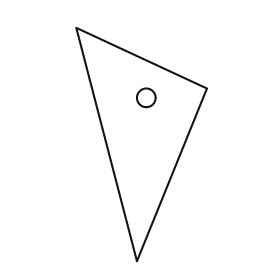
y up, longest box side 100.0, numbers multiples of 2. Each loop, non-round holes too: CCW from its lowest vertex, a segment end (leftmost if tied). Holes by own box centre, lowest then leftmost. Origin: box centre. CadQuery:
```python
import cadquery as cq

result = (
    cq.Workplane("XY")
    .moveTo(-2.0, -50.0)
    .lineTo(28.0, 24.0)
    .lineTo(-28.0, 50.0)
    .close()
    .moveTo(2.0, 20.0)
    .circle(4.0)
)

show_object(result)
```